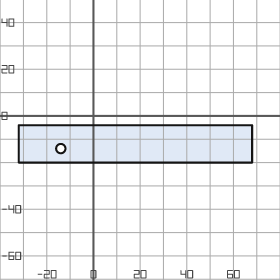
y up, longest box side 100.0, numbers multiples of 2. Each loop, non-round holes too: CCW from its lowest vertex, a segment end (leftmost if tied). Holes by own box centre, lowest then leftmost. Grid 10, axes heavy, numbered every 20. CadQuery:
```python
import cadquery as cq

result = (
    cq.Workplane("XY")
    .moveTo(-32.0, -20.0)
    .lineTo(68.0, -20.0)
    .lineTo(68.0, -4.0)
    .lineTo(-32.0, -4.0)
    .close()
    .moveTo(-14.0, -14.0)
    .circle(2.0)
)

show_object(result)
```